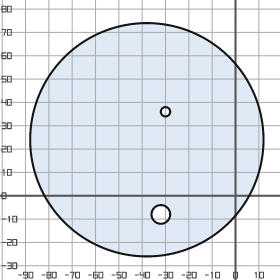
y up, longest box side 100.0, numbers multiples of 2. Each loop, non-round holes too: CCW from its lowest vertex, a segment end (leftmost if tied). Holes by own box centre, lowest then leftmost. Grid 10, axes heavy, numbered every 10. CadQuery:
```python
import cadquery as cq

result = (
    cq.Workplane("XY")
    .moveTo(-38.0, 24.0)
    .circle(50.0)
    .moveTo(-32.0, -8.0)
    .circle(4.0)
    .moveTo(-30.0, 36.0)
    .circle(2.0)
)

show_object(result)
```